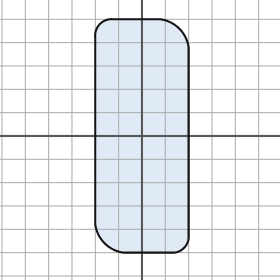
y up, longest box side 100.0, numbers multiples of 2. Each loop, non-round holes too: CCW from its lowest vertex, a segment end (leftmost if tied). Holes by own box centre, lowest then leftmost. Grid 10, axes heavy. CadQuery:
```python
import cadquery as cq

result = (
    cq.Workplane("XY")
    .moveTo(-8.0, -50.0)
    .lineTo(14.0, -50.0)
    .threePointArc((18.0, -48.0), (20.0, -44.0))
    .lineTo(20.0, 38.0)
    .threePointArc((16.0, 46.0), (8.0, 50.0))
    .lineTo(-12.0, 50.0)
    .threePointArc((-18.0, 48.0), (-20.0, 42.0))
    .lineTo(-20.0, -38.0)
    .threePointArc((-16.0, -46.0), (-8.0, -50.0))
    .close()
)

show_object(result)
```